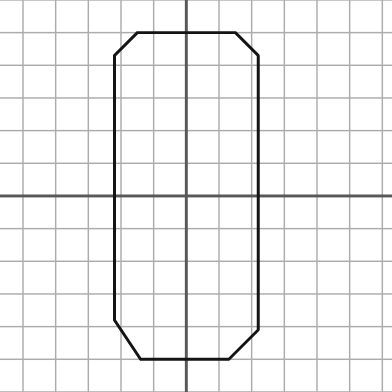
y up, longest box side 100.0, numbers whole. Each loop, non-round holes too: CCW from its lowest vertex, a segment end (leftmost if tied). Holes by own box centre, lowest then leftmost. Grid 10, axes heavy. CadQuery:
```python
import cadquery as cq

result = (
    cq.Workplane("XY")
    .moveTo(-14.0, -50.0)
    .lineTo(13.0, -50.0)
    .lineTo(22.0, -41.0)
    .lineTo(22.0, 43.0)
    .lineTo(15.0, 50.0)
    .lineTo(-15.0, 50.0)
    .lineTo(-22.0, 43.0)
    .lineTo(-22.0, -38.0)
    .close()
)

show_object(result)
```